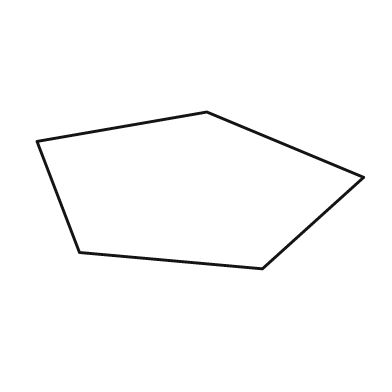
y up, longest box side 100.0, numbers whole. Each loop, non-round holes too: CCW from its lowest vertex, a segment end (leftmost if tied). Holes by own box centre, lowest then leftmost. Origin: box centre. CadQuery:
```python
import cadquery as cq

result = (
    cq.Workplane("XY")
    .moveTo(19.0, -24.0)
    .lineTo(50.0, 4.0)
    .lineTo(2.0, 24.0)
    .lineTo(-50.0, 15.0)
    .lineTo(-37.0, -19.0)
    .close()
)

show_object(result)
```